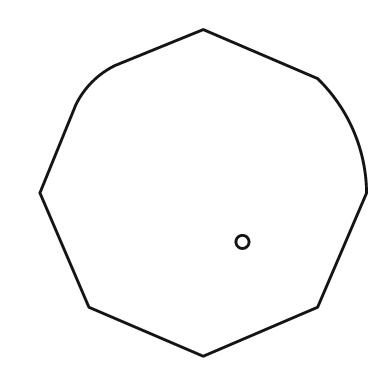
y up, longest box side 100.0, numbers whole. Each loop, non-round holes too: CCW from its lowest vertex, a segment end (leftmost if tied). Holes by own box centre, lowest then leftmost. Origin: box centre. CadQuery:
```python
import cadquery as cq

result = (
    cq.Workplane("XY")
    .moveTo(0.0, -50.0)
    .lineTo(35.0, -35.0)
    .lineTo(50.0, 0.0)
    .threePointArc((46.0, 19.0), (35.0, 35.0))
    .lineTo(0.0, 50.0)
    .lineTo(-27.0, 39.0)
    .threePointArc((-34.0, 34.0), (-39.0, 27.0))
    .lineTo(-50.0, 0.0)
    .lineTo(-35.0, -35.0)
    .close()
    .moveTo(12.0, -15.0)
    .circle(2.0)
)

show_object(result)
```